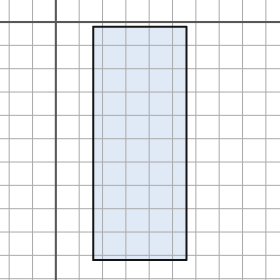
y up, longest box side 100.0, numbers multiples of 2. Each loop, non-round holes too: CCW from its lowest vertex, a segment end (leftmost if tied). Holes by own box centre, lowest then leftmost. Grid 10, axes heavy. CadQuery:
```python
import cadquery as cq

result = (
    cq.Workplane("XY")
    .moveTo(16.0, -102.0)
    .lineTo(56.0, -102.0)
    .lineTo(56.0, -2.0)
    .lineTo(16.0, -2.0)
    .close()
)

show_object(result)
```